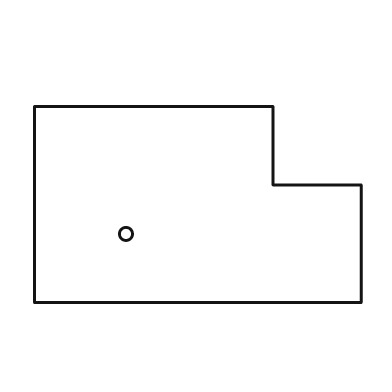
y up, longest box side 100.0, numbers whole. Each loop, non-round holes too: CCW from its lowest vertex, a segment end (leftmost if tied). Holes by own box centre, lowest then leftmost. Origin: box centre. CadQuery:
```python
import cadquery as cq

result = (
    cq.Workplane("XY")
    .moveTo(-50.0, -30.0)
    .lineTo(50.0, -30.0)
    .lineTo(50.0, 6.0)
    .lineTo(23.0, 6.0)
    .lineTo(23.0, 30.0)
    .lineTo(-50.0, 30.0)
    .close()
    .moveTo(-22.0, -9.0)
    .circle(2.0)
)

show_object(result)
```